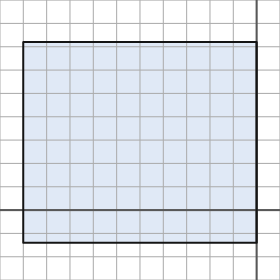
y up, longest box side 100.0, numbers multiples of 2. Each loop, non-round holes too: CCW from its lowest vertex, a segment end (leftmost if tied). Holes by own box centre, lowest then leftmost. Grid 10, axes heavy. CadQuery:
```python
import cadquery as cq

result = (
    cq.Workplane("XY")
    .moveTo(-100.0, -14.0)
    .lineTo(0.0, -14.0)
    .lineTo(0.0, 72.0)
    .lineTo(-100.0, 72.0)
    .close()
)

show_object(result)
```